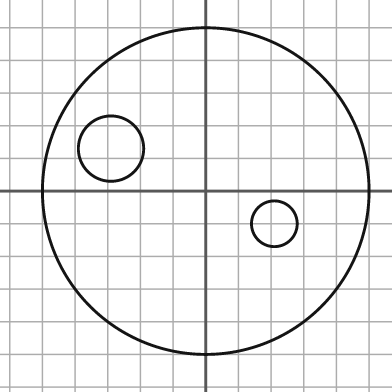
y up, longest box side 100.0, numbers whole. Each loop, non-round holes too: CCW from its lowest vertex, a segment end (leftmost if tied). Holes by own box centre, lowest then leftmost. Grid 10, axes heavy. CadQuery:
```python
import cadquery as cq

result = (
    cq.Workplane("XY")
    .moveTo(0.0, 0.0)
    .circle(50.0)
    .moveTo(21.0, -10.0)
    .circle(7.0)
    .moveTo(-29.0, 13.0)
    .circle(10.0)
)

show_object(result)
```